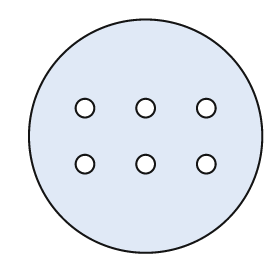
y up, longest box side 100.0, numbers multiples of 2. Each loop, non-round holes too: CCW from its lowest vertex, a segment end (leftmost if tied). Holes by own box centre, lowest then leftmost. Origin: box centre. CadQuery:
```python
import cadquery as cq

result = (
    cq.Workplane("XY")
    .moveTo(0.0, 0.0)
    .circle(50.0)
    .moveTo(-26.0, -12.0)
    .circle(4.0)
    .moveTo(0.0, -12.0)
    .circle(4.0)
    .moveTo(26.0, -12.0)
    .circle(4.0)
    .moveTo(-26.0, 12.0)
    .circle(4.0)
    .moveTo(0.0, 12.0)
    .circle(4.0)
    .moveTo(26.0, 12.0)
    .circle(4.0)
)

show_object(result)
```